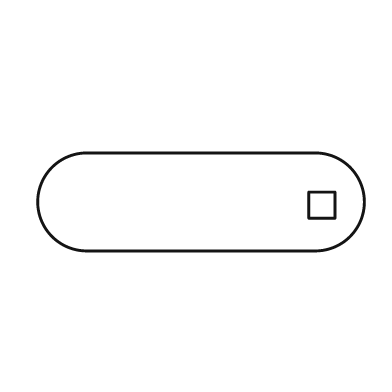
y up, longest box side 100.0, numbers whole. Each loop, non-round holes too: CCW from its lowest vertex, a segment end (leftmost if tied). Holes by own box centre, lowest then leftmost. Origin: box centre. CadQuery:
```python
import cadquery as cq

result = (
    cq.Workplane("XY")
    .moveTo(-35.0, -15.0)
    .lineTo(35.0, -15.0)
    .threePointArc((50.0, 0.0), (35.0, 15.0))
    .lineTo(-35.0, 15.0)
    .threePointArc((-50.0, 0.0), (-35.0, -15.0))
    .close()
    .moveTo(33.0, -5.0)
    .lineTo(41.0, -5.0)
    .lineTo(41.0, 3.0)
    .lineTo(33.0, 3.0)
    .close()
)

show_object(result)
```